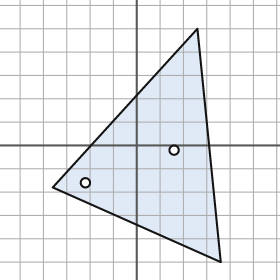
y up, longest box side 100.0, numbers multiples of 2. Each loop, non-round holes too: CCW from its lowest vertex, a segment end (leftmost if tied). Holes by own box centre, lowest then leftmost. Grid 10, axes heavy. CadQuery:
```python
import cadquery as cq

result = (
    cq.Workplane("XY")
    .moveTo(36.0, -50.0)
    .lineTo(26.0, 50.0)
    .lineTo(-36.0, -18.0)
    .close()
    .moveTo(-22.0, -16.0)
    .circle(2.0)
    .moveTo(16.0, -2.0)
    .circle(2.0)
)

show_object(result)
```